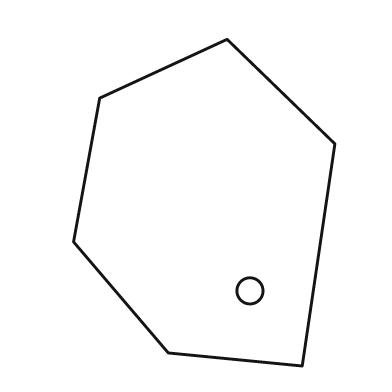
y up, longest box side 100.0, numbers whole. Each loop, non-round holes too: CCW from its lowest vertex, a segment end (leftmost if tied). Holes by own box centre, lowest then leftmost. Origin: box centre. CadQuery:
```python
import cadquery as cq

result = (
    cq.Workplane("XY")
    .moveTo(30.0, -50.0)
    .lineTo(40.0, 18.0)
    .lineTo(7.0, 50.0)
    .lineTo(-32.0, 32.0)
    .lineTo(-40.0, -12.0)
    .lineTo(-11.0, -46.0)
    .close()
    .moveTo(14.0, -27.0)
    .circle(4.0)
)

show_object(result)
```